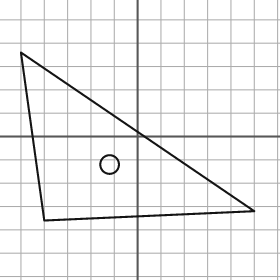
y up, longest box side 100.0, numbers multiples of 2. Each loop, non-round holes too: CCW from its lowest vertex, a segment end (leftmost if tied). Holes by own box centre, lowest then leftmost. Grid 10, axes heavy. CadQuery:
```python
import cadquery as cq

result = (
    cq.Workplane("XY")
    .moveTo(-40.0, -36.0)
    .lineTo(50.0, -32.0)
    .lineTo(-50.0, 36.0)
    .close()
    .moveTo(-12.0, -12.0)
    .circle(4.0)
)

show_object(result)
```